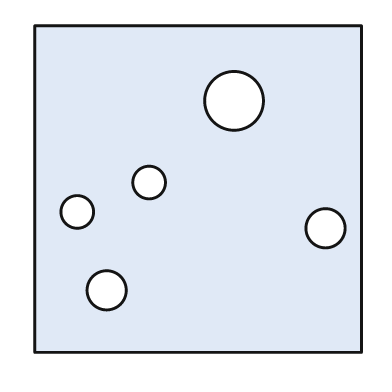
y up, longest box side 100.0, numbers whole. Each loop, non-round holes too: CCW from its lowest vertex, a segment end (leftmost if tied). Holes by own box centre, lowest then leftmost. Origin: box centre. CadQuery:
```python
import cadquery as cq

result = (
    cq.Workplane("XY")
    .moveTo(-50.0, -50.0)
    .lineTo(50.0, -50.0)
    .lineTo(50.0, 50.0)
    .lineTo(-50.0, 50.0)
    .close()
    .moveTo(-28.0, -31.0)
    .circle(6.0)
    .moveTo(39.0, -12.0)
    .circle(6.0)
    .moveTo(-37.0, -7.0)
    .circle(5.0)
    .moveTo(-15.0, 2.0)
    .circle(5.0)
    .moveTo(11.0, 27.0)
    .circle(9.0)
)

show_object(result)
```